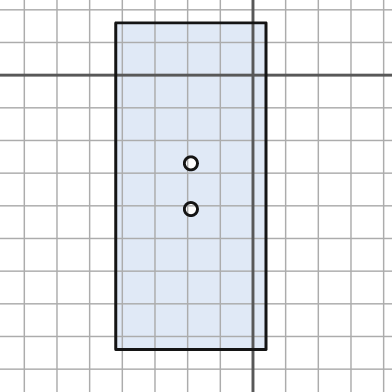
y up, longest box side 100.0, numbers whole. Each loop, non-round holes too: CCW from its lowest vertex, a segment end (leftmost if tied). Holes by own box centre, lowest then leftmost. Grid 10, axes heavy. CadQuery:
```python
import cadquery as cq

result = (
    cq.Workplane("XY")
    .moveTo(-42.0, -84.0)
    .lineTo(4.0, -84.0)
    .lineTo(4.0, 16.0)
    .lineTo(-42.0, 16.0)
    .close()
    .moveTo(-19.0, -41.0)
    .circle(2.0)
    .moveTo(-19.0, -27.0)
    .circle(2.0)
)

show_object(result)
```